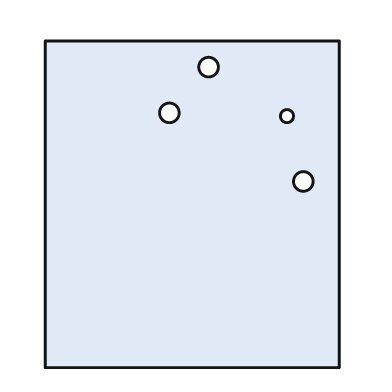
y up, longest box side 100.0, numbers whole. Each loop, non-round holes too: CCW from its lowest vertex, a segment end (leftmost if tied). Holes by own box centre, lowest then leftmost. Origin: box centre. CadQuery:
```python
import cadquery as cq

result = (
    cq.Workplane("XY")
    .moveTo(-45.0, -50.0)
    .lineTo(45.0, -50.0)
    .lineTo(45.0, 50.0)
    .lineTo(-45.0, 50.0)
    .close()
    .moveTo(34.0, 7.0)
    .circle(3.0)
    .moveTo(29.0, 27.0)
    .circle(2.0)
    .moveTo(-7.0, 28.0)
    .circle(3.0)
    .moveTo(5.0, 42.0)
    .circle(3.0)
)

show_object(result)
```